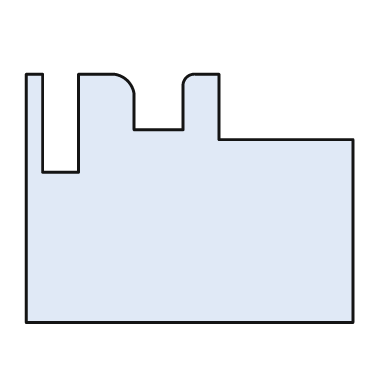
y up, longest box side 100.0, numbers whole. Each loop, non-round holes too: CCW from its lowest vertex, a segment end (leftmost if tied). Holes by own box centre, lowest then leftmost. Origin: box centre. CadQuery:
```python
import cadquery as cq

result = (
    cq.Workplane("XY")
    .moveTo(-50.0, -38.0)
    .lineTo(50.0, -38.0)
    .lineTo(50.0, 18.0)
    .lineTo(9.0, 18.0)
    .lineTo(9.0, 38.0)
    .lineTo(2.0, 38.0)
    .threePointArc((-1.0, 37.0), (-2.0, 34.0))
    .lineTo(-2.0, 21.0)
    .lineTo(-17.0, 21.0)
    .lineTo(-17.0, 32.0)
    .threePointArc((-19.0, 36.0), (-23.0, 38.0))
    .lineTo(-34.0, 38.0)
    .lineTo(-34.0, 8.0)
    .lineTo(-45.0, 8.0)
    .lineTo(-45.0, 38.0)
    .lineTo(-50.0, 38.0)
    .close()
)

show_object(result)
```